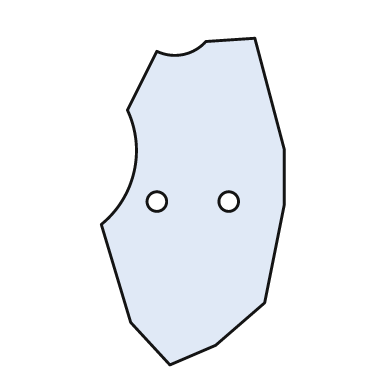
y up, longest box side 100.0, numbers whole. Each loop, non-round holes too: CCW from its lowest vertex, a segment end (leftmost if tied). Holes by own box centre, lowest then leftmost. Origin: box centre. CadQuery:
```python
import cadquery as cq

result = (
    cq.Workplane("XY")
    .moveTo(-7.0, -50.0)
    .lineTo(7.0, -44.0)
    .lineTo(22.0, -31.0)
    .lineTo(28.0, -1.0)
    .lineTo(28.0, 16.0)
    .lineTo(19.0, 50.0)
    .lineTo(4.0, 49.0)
    .threePointArc((-3.0, 45.0), (-11.0, 46.0))
    .lineTo(-20.0, 28.0)
    .threePointArc((-18.0, 9.0), (-28.0, -7.0))
    .lineTo(-19.0, -37.0)
    .close()
    .moveTo(-11.0, 0.0)
    .circle(3.0)
    .moveTo(11.0, 0.0)
    .circle(3.0)
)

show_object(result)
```